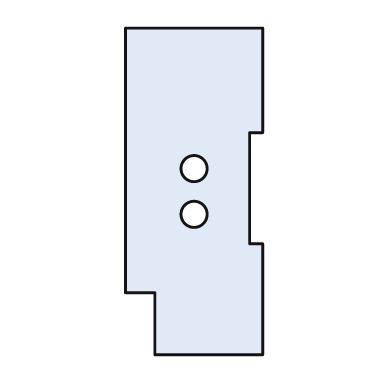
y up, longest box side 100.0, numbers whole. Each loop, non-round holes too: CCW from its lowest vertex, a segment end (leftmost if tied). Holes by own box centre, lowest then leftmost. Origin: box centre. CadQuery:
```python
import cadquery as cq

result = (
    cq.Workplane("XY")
    .moveTo(-12.0, -50.0)
    .lineTo(21.0, -50.0)
    .lineTo(21.0, -16.0)
    .lineTo(17.0, -16.0)
    .lineTo(17.0, 18.0)
    .lineTo(21.0, 18.0)
    .lineTo(21.0, 50.0)
    .lineTo(-21.0, 50.0)
    .lineTo(-21.0, -31.0)
    .lineTo(-12.0, -31.0)
    .close()
    .moveTo(0.0, -7.0)
    .circle(4.0)
    .moveTo(0.0, 7.0)
    .circle(4.0)
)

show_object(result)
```